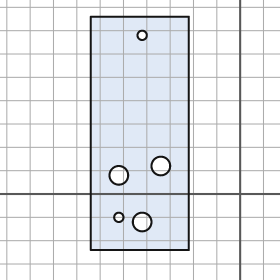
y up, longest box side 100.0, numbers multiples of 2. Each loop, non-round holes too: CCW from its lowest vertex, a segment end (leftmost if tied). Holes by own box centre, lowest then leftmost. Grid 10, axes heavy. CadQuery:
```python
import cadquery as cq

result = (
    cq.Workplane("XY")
    .moveTo(-64.0, -24.0)
    .lineTo(-22.0, -24.0)
    .lineTo(-22.0, 76.0)
    .lineTo(-64.0, 76.0)
    .close()
    .moveTo(-42.0, -12.0)
    .circle(4.0)
    .moveTo(-52.0, -10.0)
    .circle(2.0)
    .moveTo(-52.0, 8.0)
    .circle(4.0)
    .moveTo(-34.0, 12.0)
    .circle(4.0)
    .moveTo(-42.0, 68.0)
    .circle(2.0)
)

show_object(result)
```